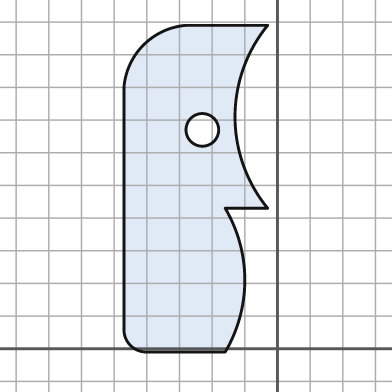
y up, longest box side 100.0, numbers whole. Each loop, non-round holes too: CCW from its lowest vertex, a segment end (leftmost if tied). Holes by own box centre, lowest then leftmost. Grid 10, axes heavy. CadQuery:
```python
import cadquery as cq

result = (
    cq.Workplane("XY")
    .moveTo(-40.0, -1.0)
    .lineTo(-16.0, -1.0)
    .threePointArc((-10.0, 21.0), (-16.0, 43.0))
    .lineTo(-3.0, 43.0)
    .threePointArc((-13.0, 71.0), (-3.0, 99.0))
    .lineTo(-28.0, 99.0)
    .threePointArc((-41.0, 93.0), (-47.0, 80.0))
    .lineTo(-47.0, 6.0)
    .threePointArc((-45.0, 1.0), (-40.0, -1.0))
    .close()
    .moveTo(-23.0, 67.0)
    .circle(5.0)
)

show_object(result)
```